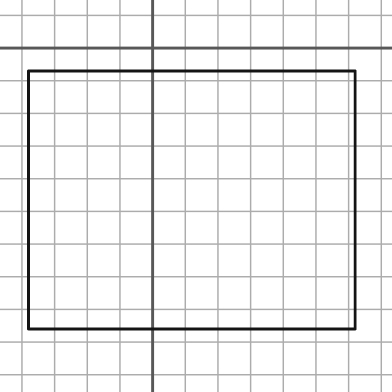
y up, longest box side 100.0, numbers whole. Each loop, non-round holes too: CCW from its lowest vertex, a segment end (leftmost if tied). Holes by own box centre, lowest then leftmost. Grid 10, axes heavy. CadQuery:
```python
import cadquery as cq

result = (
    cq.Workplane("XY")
    .moveTo(-38.0, -86.0)
    .lineTo(62.0, -86.0)
    .lineTo(62.0, -7.0)
    .lineTo(-38.0, -7.0)
    .close()
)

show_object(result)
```